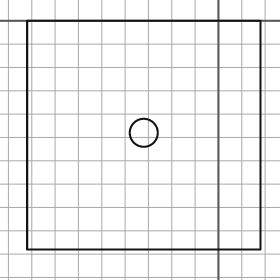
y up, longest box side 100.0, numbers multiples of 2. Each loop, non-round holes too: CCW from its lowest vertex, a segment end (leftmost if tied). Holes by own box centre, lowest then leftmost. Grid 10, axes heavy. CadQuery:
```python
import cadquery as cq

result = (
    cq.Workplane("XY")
    .moveTo(-82.0, -98.0)
    .lineTo(18.0, -98.0)
    .lineTo(18.0, 0.0)
    .lineTo(-82.0, 0.0)
    .close()
    .moveTo(-32.0, -48.0)
    .circle(6.0)
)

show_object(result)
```